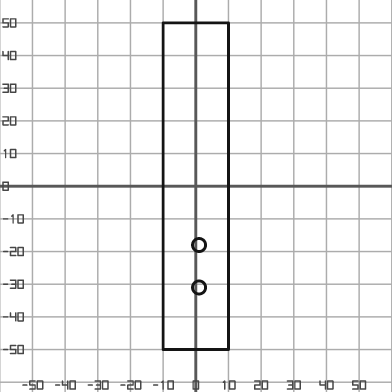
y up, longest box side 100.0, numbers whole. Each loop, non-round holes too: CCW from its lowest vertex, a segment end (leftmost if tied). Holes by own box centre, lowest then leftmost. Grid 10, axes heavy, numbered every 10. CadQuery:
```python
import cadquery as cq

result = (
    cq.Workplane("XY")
    .moveTo(-10.0, -50.0)
    .lineTo(10.0, -50.0)
    .lineTo(10.0, 50.0)
    .lineTo(-10.0, 50.0)
    .close()
    .moveTo(1.0, -31.0)
    .circle(2.0)
    .moveTo(1.0, -18.0)
    .circle(2.0)
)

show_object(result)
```